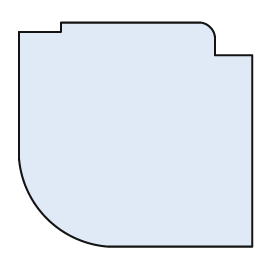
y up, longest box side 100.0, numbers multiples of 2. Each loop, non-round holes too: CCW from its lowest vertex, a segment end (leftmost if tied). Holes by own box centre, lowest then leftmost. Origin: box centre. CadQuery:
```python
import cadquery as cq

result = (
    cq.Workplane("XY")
    .moveTo(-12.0, -48.0)
    .lineTo(50.0, -48.0)
    .lineTo(50.0, 34.0)
    .lineTo(34.0, 34.0)
    .lineTo(34.0, 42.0)
    .threePointArc((32.0, 46.0), (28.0, 48.0))
    .lineTo(-32.0, 48.0)
    .lineTo(-32.0, 44.0)
    .lineTo(-50.0, 44.0)
    .lineTo(-50.0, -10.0)
    .threePointArc((-38.0, -36.0), (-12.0, -48.0))
    .close()
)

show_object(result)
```